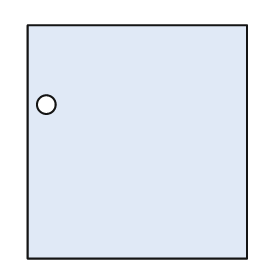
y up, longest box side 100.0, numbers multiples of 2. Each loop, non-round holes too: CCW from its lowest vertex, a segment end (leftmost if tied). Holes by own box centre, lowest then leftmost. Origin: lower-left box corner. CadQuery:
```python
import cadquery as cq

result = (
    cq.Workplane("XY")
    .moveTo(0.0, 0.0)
    .lineTo(94.0, 0.0)
    .lineTo(94.0, 100.0)
    .lineTo(0.0, 100.0)
    .close()
    .moveTo(8.0, 66.0)
    .circle(4.0)
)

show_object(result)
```